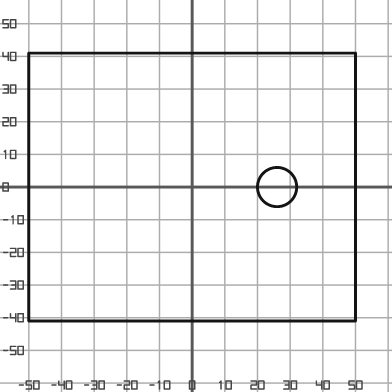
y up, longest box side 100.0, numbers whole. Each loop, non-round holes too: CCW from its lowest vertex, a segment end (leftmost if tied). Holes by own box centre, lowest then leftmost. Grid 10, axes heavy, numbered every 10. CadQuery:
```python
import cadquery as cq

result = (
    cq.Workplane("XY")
    .moveTo(-50.0, -41.0)
    .lineTo(50.0, -41.0)
    .lineTo(50.0, 41.0)
    .lineTo(-50.0, 41.0)
    .close()
    .moveTo(26.0, 0.0)
    .circle(6.0)
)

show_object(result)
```